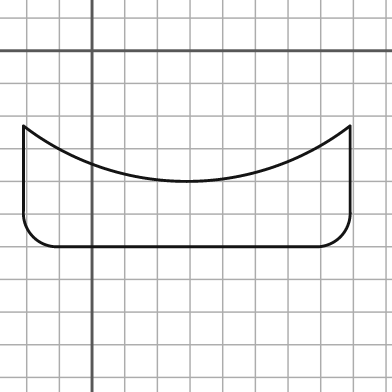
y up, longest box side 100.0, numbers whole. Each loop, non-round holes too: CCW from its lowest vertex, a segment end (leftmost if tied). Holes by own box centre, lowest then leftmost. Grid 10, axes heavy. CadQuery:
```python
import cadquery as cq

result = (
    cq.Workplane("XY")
    .moveTo(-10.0, -60.0)
    .lineTo(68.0, -60.0)
    .threePointArc((76.0, -57.0), (79.0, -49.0))
    .lineTo(79.0, -23.0)
    .threePointArc((29.0, -40.0), (-21.0, -23.0))
    .lineTo(-21.0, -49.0)
    .threePointArc((-18.0, -57.0), (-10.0, -60.0))
    .close()
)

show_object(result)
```